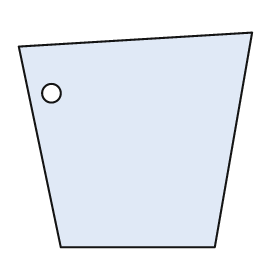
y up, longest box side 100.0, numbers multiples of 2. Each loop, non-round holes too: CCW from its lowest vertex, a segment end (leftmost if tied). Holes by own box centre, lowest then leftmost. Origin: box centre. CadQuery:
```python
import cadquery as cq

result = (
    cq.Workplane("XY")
    .moveTo(-32.0, -46.0)
    .lineTo(34.0, -46.0)
    .lineTo(50.0, 46.0)
    .lineTo(-50.0, 40.0)
    .close()
    .moveTo(-36.0, 20.0)
    .circle(4.0)
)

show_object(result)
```